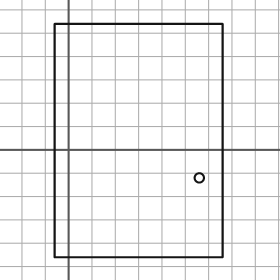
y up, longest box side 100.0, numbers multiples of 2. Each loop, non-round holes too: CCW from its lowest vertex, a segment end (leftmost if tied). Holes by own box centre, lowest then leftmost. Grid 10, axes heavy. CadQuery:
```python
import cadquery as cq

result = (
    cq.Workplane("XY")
    .moveTo(-6.0, -46.0)
    .lineTo(66.0, -46.0)
    .lineTo(66.0, 54.0)
    .lineTo(-6.0, 54.0)
    .close()
    .moveTo(56.0, -12.0)
    .circle(2.0)
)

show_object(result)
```